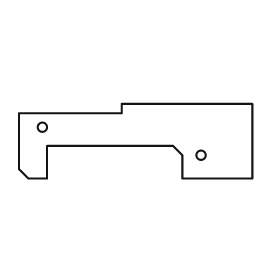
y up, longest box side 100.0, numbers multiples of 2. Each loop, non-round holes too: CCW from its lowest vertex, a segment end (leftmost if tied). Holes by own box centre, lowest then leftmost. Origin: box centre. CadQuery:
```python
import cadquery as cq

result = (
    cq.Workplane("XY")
    .moveTo(-46.0, -16.0)
    .lineTo(-38.0, -16.0)
    .lineTo(-38.0, -2.0)
    .lineTo(16.0, -2.0)
    .lineTo(20.0, -6.0)
    .lineTo(20.0, -16.0)
    .lineTo(50.0, -16.0)
    .lineTo(50.0, 16.0)
    .lineTo(-6.0, 16.0)
    .lineTo(-6.0, 12.0)
    .lineTo(-50.0, 12.0)
    .lineTo(-50.0, -12.0)
    .close()
    .moveTo(28.0, -6.0)
    .circle(2.0)
    .moveTo(-40.0, 6.0)
    .circle(2.0)
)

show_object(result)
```